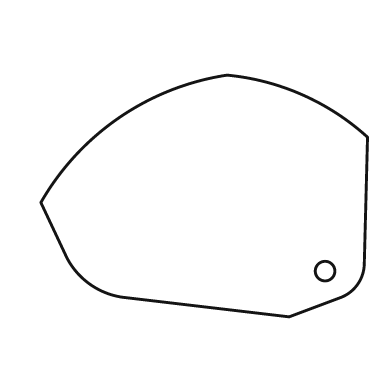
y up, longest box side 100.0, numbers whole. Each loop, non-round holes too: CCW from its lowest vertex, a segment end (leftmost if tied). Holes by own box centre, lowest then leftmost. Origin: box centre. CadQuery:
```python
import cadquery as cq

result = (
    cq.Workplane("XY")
    .moveTo(26.0, -37.0)
    .lineTo(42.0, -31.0)
    .threePointArc((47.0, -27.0), (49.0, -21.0))
    .lineTo(50.0, 18.0)
    .threePointArc((30.0, 31.0), (7.0, 37.0))
    .threePointArc((-26.0, 24.0), (-50.0, -2.0))
    .lineTo(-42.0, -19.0)
    .threePointArc((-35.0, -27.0), (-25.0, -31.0))
    .close()
    .moveTo(37.0, -23.0)
    .circle(3.0)
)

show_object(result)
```